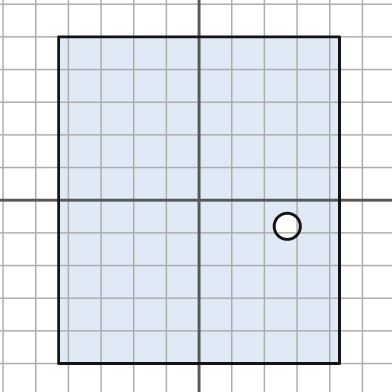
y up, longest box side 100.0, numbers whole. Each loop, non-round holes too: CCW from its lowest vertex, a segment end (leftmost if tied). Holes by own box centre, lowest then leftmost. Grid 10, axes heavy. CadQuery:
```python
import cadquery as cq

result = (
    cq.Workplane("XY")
    .moveTo(-43.0, -50.0)
    .lineTo(43.0, -50.0)
    .lineTo(43.0, 50.0)
    .lineTo(-43.0, 50.0)
    .close()
    .moveTo(27.0, -8.0)
    .circle(4.0)
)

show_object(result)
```